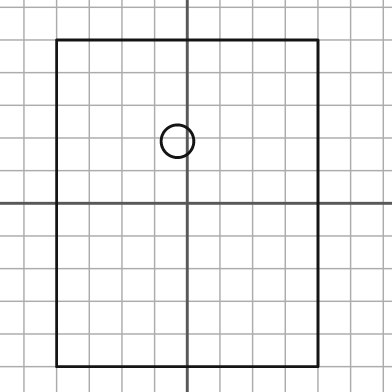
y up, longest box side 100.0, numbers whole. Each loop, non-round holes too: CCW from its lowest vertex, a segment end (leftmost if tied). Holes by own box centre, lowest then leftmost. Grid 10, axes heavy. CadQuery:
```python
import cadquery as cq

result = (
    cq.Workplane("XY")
    .moveTo(-40.0, -50.0)
    .lineTo(40.0, -50.0)
    .lineTo(40.0, 50.0)
    .lineTo(-40.0, 50.0)
    .close()
    .moveTo(-3.0, 19.0)
    .circle(5.0)
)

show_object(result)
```